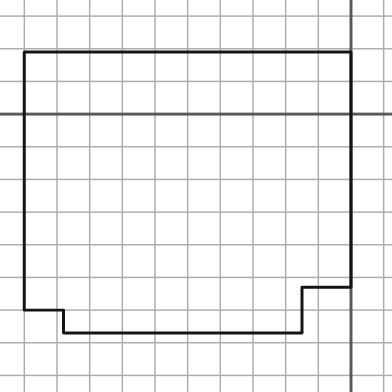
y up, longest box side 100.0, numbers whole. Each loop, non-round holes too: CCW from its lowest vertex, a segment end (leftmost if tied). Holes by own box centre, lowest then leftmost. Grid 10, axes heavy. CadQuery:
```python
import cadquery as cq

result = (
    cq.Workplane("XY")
    .moveTo(-88.0, -67.0)
    .lineTo(-15.0, -67.0)
    .lineTo(-15.0, -53.0)
    .lineTo(0.0, -53.0)
    .lineTo(0.0, 19.0)
    .lineTo(-100.0, 19.0)
    .lineTo(-100.0, -60.0)
    .lineTo(-88.0, -60.0)
    .close()
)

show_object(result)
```